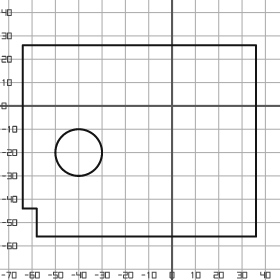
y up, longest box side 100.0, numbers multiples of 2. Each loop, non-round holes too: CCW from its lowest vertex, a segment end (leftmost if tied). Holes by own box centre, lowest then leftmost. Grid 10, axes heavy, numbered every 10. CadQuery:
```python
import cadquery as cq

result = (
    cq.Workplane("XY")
    .moveTo(-58.0, -56.0)
    .lineTo(36.0, -56.0)
    .lineTo(36.0, 26.0)
    .lineTo(-64.0, 26.0)
    .lineTo(-64.0, -44.0)
    .lineTo(-58.0, -44.0)
    .close()
    .moveTo(-40.0, -20.0)
    .circle(10.0)
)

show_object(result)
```